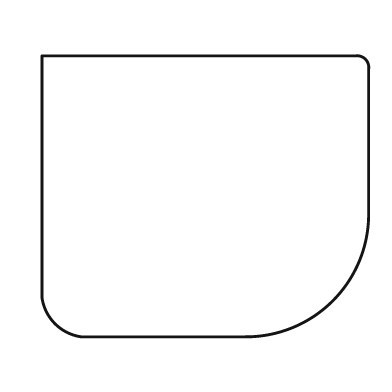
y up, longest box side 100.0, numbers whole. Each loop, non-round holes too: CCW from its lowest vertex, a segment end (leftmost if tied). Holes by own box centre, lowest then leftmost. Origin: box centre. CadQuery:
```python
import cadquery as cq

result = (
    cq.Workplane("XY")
    .moveTo(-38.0, -43.0)
    .lineTo(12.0, -43.0)
    .threePointArc((39.0, -32.0), (50.0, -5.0))
    .lineTo(50.0, 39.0)
    .threePointArc((49.0, 42.0), (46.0, 43.0))
    .lineTo(-50.0, 43.0)
    .lineTo(-50.0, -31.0)
    .threePointArc((-46.0, -39.0), (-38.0, -43.0))
    .close()
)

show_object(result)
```